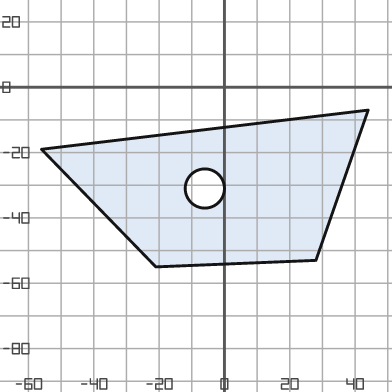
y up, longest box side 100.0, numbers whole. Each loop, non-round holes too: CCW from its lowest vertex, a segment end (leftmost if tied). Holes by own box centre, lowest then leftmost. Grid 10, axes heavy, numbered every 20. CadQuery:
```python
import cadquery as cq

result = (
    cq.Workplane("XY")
    .moveTo(-21.0, -55.0)
    .lineTo(28.0, -53.0)
    .lineTo(44.0, -7.0)
    .lineTo(-56.0, -19.0)
    .close()
    .moveTo(-6.0, -31.0)
    .circle(6.0)
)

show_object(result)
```